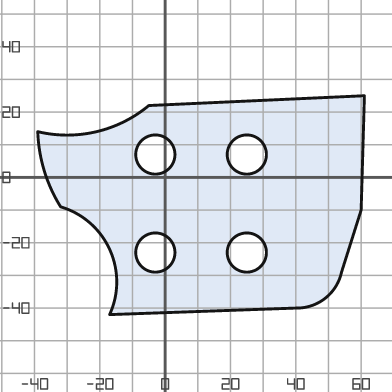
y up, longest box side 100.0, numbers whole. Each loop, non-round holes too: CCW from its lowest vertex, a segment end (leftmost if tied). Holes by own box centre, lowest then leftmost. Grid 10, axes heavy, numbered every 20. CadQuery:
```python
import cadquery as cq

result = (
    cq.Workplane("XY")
    .moveTo(-17.0, -42.0)
    .lineTo(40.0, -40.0)
    .threePointArc((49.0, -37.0), (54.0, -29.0))
    .lineTo(60.0, -10.0)
    .lineTo(61.0, 25.0)
    .lineTo(-5.0, 22.0)
    .threePointArc((-21.0, 14.0), (-39.0, 14.0))
    .threePointArc((-37.0, 2.0), (-32.0, -9.0))
    .threePointArc((-17.0, -22.0), (-17.0, -42.0))
    .close()
    .moveTo(-3.0, -23.0)
    .circle(6.0)
    .moveTo(25.0, -23.0)
    .circle(6.0)
    .moveTo(-3.0, 7.0)
    .circle(6.0)
    .moveTo(25.0, 7.0)
    .circle(6.0)
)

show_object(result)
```